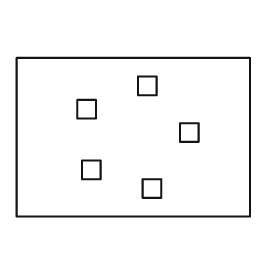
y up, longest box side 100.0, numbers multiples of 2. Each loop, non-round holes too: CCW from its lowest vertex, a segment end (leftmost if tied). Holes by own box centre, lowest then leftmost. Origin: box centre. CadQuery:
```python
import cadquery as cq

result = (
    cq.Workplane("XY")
    .moveTo(-50.0, -34.0)
    .lineTo(50.0, -34.0)
    .lineTo(50.0, 34.0)
    .lineTo(-50.0, 34.0)
    .close()
    .moveTo(4.0, -26.0)
    .lineTo(12.0, -26.0)
    .lineTo(12.0, -18.0)
    .lineTo(4.0, -18.0)
    .close()
    .moveTo(-22.0, -18.0)
    .lineTo(-14.0, -18.0)
    .lineTo(-14.0, -10.0)
    .lineTo(-22.0, -10.0)
    .close()
    .moveTo(20.0, -2.0)
    .lineTo(28.0, -2.0)
    .lineTo(28.0, 6.0)
    .lineTo(20.0, 6.0)
    .close()
    .moveTo(-24.0, 8.0)
    .lineTo(-16.0, 8.0)
    .lineTo(-16.0, 16.0)
    .lineTo(-24.0, 16.0)
    .close()
    .moveTo(2.0, 18.0)
    .lineTo(10.0, 18.0)
    .lineTo(10.0, 26.0)
    .lineTo(2.0, 26.0)
    .close()
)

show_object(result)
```